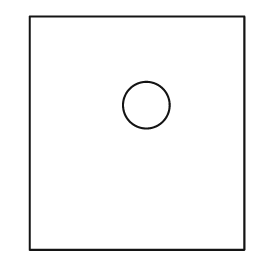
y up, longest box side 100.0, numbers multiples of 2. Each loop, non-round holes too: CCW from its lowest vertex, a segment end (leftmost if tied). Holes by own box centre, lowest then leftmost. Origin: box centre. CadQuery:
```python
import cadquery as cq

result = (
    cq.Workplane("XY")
    .moveTo(-46.0, -50.0)
    .lineTo(46.0, -50.0)
    .lineTo(46.0, 50.0)
    .lineTo(-46.0, 50.0)
    .close()
    .moveTo(4.0, 12.0)
    .circle(10.0)
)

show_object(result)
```